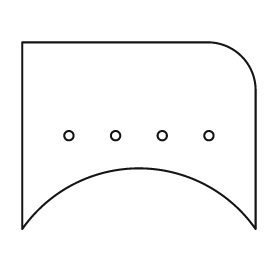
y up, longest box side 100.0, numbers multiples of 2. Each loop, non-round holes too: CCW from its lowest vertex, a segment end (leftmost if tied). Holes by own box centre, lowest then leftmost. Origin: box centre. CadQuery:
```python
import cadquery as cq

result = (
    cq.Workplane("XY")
    .moveTo(-50.0, -40.0)
    .threePointArc((0.0, -14.0), (50.0, -40.0))
    .lineTo(50.0, 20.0)
    .threePointArc((44.0, 34.0), (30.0, 40.0))
    .lineTo(-50.0, 40.0)
    .close()
    .moveTo(-30.0, 0.0)
    .circle(2.0)
    .moveTo(-10.0, 0.0)
    .circle(2.0)
    .moveTo(10.0, 0.0)
    .circle(2.0)
    .moveTo(30.0, 0.0)
    .circle(2.0)
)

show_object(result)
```